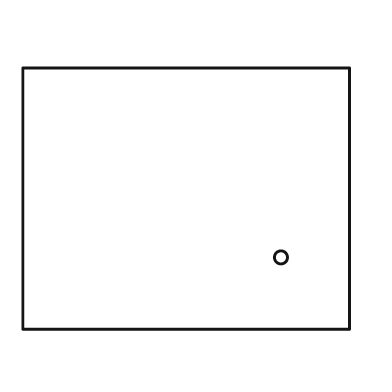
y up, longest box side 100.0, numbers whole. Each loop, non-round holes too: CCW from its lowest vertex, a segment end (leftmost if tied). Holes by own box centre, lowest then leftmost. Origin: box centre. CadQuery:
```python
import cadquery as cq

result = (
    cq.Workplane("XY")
    .moveTo(-50.0, -40.0)
    .lineTo(50.0, -40.0)
    .lineTo(50.0, 40.0)
    .lineTo(-50.0, 40.0)
    .close()
    .moveTo(29.0, -18.0)
    .circle(2.0)
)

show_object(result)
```